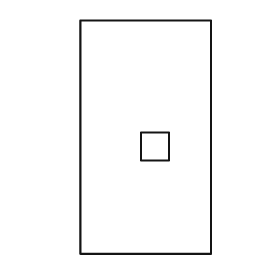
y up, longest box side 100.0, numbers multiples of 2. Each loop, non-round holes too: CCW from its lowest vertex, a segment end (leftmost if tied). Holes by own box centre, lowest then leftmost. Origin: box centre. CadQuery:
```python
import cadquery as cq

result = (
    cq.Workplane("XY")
    .moveTo(-28.0, -50.0)
    .lineTo(28.0, -50.0)
    .lineTo(28.0, 50.0)
    .lineTo(-28.0, 50.0)
    .close()
    .moveTo(-2.0, -10.0)
    .lineTo(10.0, -10.0)
    .lineTo(10.0, 2.0)
    .lineTo(-2.0, 2.0)
    .close()
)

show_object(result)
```